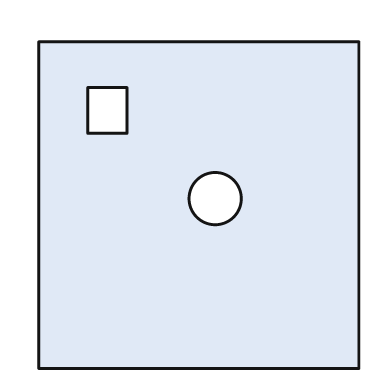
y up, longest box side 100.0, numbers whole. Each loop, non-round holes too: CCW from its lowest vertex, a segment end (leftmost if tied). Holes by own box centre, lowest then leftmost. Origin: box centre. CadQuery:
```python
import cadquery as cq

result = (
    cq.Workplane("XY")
    .moveTo(-49.0, -50.0)
    .lineTo(49.0, -50.0)
    .lineTo(49.0, 50.0)
    .lineTo(-49.0, 50.0)
    .close()
    .moveTo(5.0, 2.0)
    .circle(8.0)
    .moveTo(-34.0, 22.0)
    .lineTo(-22.0, 22.0)
    .lineTo(-22.0, 36.0)
    .lineTo(-34.0, 36.0)
    .close()
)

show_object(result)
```